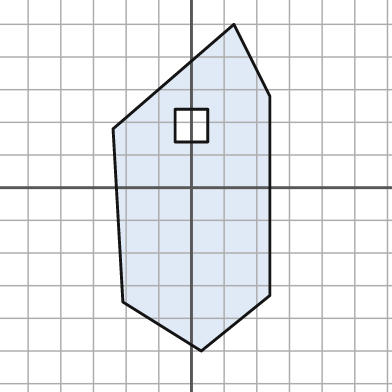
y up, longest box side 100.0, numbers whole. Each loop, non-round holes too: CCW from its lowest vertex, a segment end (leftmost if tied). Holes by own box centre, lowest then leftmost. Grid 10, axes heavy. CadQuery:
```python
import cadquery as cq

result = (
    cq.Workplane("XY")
    .moveTo(3.0, -50.0)
    .lineTo(24.0, -33.0)
    .lineTo(24.0, 28.0)
    .lineTo(13.0, 50.0)
    .lineTo(-24.0, 18.0)
    .lineTo(-21.0, -35.0)
    .close()
    .moveTo(-5.0, 14.0)
    .lineTo(5.0, 14.0)
    .lineTo(5.0, 24.0)
    .lineTo(-5.0, 24.0)
    .close()
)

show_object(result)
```